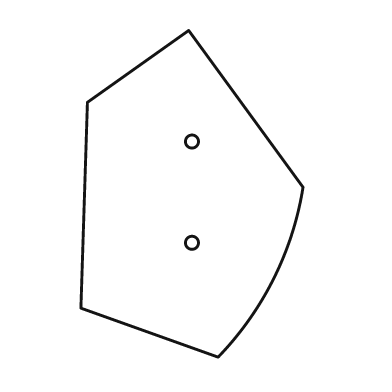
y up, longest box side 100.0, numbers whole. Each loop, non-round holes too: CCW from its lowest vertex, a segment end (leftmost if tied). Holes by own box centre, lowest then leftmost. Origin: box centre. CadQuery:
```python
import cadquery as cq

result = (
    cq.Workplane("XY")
    .moveTo(8.0, -50.0)
    .threePointArc((25.0, -26.0), (34.0, 2.0))
    .lineTo(-1.0, 50.0)
    .lineTo(-32.0, 28.0)
    .lineTo(-34.0, -35.0)
    .close()
    .moveTo(0.0, -15.0)
    .circle(2.0)
    .moveTo(0.0, 16.0)
    .circle(2.0)
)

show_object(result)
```